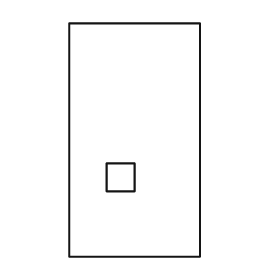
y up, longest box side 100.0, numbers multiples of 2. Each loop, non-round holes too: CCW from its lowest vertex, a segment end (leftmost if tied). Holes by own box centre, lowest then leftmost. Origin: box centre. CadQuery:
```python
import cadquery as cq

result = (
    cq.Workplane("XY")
    .moveTo(-28.0, -50.0)
    .lineTo(28.0, -50.0)
    .lineTo(28.0, 50.0)
    .lineTo(-28.0, 50.0)
    .close()
    .moveTo(-12.0, -22.0)
    .lineTo(0.0, -22.0)
    .lineTo(0.0, -10.0)
    .lineTo(-12.0, -10.0)
    .close()
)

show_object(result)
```